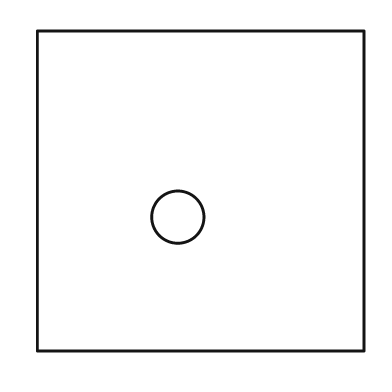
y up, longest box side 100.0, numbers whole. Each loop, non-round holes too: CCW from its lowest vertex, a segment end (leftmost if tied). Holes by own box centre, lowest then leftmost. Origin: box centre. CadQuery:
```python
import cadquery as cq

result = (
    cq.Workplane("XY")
    .moveTo(-50.0, -49.0)
    .lineTo(50.0, -49.0)
    .lineTo(50.0, 49.0)
    .lineTo(-50.0, 49.0)
    .close()
    .moveTo(-7.0, -8.0)
    .circle(8.0)
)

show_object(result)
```